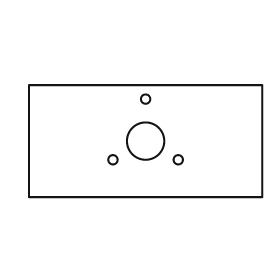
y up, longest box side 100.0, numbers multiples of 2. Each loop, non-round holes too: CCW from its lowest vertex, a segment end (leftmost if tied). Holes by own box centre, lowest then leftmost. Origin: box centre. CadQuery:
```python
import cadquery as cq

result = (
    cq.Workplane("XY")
    .moveTo(-50.0, -24.0)
    .lineTo(50.0, -24.0)
    .lineTo(50.0, 24.0)
    .lineTo(-50.0, 24.0)
    .close()
    .moveTo(-14.0, -8.0)
    .circle(2.0)
    .moveTo(14.0, -8.0)
    .circle(2.0)
    .moveTo(0.0, 0.0)
    .circle(8.0)
    .moveTo(0.0, 18.0)
    .circle(2.0)
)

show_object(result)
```